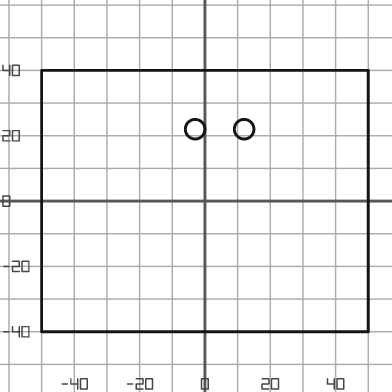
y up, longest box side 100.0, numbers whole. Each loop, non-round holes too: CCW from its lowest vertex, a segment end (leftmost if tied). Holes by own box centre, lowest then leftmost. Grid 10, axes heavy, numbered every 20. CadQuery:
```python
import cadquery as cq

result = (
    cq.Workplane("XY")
    .moveTo(-50.0, -40.0)
    .lineTo(50.0, -40.0)
    .lineTo(50.0, 40.0)
    .lineTo(-50.0, 40.0)
    .close()
    .moveTo(-3.0, 22.0)
    .circle(3.0)
    .moveTo(12.0, 22.0)
    .circle(3.0)
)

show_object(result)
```